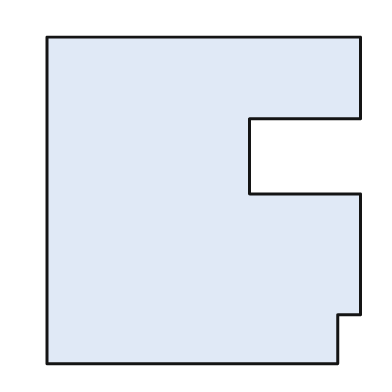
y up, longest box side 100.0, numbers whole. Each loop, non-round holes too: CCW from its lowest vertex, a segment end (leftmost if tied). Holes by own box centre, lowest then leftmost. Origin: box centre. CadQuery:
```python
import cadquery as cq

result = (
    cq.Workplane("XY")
    .moveTo(-48.0, -50.0)
    .lineTo(41.0, -50.0)
    .lineTo(41.0, -35.0)
    .lineTo(48.0, -35.0)
    .lineTo(48.0, 2.0)
    .lineTo(14.0, 2.0)
    .lineTo(14.0, 25.0)
    .lineTo(48.0, 25.0)
    .lineTo(48.0, 50.0)
    .lineTo(-48.0, 50.0)
    .close()
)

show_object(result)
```